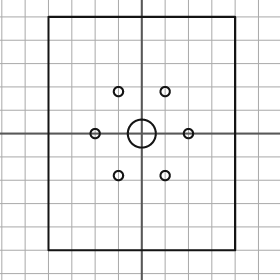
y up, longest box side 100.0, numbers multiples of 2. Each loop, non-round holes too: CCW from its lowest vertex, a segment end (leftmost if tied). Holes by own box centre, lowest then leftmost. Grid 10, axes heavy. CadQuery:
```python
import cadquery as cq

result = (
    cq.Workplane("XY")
    .moveTo(-40.0, -50.0)
    .lineTo(40.0, -50.0)
    .lineTo(40.0, 50.0)
    .lineTo(-40.0, 50.0)
    .close()
    .moveTo(-10.0, -18.0)
    .circle(2.0)
    .moveTo(10.0, -18.0)
    .circle(2.0)
    .moveTo(-20.0, 0.0)
    .circle(2.0)
    .moveTo(0.0, 0.0)
    .circle(6.0)
    .moveTo(20.0, 0.0)
    .circle(2.0)
    .moveTo(-10.0, 18.0)
    .circle(2.0)
    .moveTo(10.0, 18.0)
    .circle(2.0)
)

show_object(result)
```